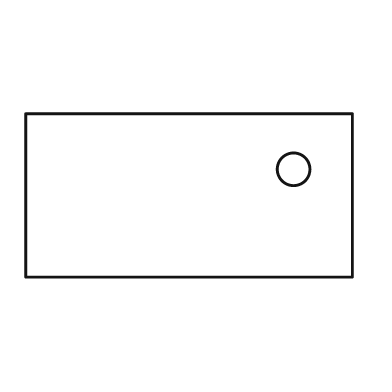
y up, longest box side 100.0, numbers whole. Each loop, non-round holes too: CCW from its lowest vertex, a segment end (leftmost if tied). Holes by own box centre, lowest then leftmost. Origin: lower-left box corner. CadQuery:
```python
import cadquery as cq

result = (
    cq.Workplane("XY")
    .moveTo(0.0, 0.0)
    .lineTo(100.0, 0.0)
    .lineTo(100.0, 50.0)
    .lineTo(0.0, 50.0)
    .close()
    .moveTo(82.0, 33.0)
    .circle(5.0)
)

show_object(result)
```